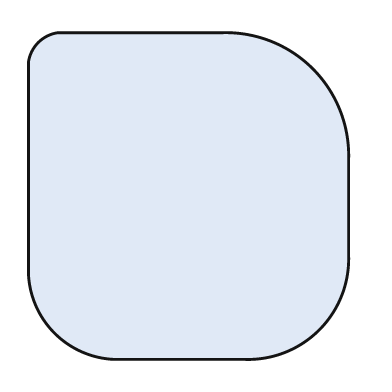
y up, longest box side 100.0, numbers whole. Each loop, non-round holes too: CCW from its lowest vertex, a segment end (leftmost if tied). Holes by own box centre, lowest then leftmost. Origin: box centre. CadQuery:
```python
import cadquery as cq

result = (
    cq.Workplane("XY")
    .moveTo(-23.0, -50.0)
    .lineTo(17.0, -50.0)
    .threePointArc((40.0, -41.0), (49.0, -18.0))
    .lineTo(49.0, 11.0)
    .threePointArc((38.0, 39.0), (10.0, 50.0))
    .lineTo(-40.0, 50.0)
    .threePointArc((-46.0, 47.0), (-49.0, 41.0))
    .lineTo(-49.0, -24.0)
    .threePointArc((-41.0, -42.0), (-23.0, -50.0))
    .close()
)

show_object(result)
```